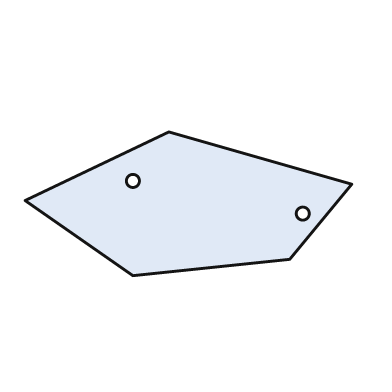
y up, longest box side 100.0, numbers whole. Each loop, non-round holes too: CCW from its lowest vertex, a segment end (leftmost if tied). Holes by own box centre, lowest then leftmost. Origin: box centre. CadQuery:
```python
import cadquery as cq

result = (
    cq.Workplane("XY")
    .moveTo(-17.0, -22.0)
    .lineTo(31.0, -17.0)
    .lineTo(50.0, 6.0)
    .lineTo(-6.0, 22.0)
    .lineTo(-50.0, 1.0)
    .close()
    .moveTo(35.0, -3.0)
    .circle(2.0)
    .moveTo(-17.0, 7.0)
    .circle(2.0)
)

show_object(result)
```